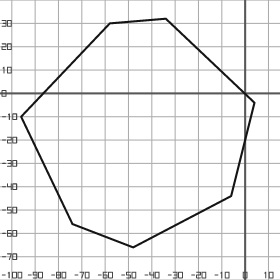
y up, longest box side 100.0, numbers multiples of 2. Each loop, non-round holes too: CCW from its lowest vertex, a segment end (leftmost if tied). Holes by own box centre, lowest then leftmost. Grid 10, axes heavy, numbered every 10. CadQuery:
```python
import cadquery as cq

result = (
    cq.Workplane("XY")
    .moveTo(-48.0, -66.0)
    .lineTo(-6.0, -44.0)
    .lineTo(4.0, -4.0)
    .lineTo(-34.0, 32.0)
    .lineTo(-58.0, 30.0)
    .lineTo(-96.0, -10.0)
    .lineTo(-74.0, -56.0)
    .close()
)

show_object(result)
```